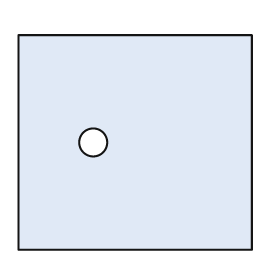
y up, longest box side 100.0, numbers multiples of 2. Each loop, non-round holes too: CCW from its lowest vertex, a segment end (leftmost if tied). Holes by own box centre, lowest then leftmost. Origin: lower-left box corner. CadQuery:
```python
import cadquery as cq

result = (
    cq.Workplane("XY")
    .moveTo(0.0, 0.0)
    .lineTo(100.0, 0.0)
    .lineTo(100.0, 92.0)
    .lineTo(0.0, 92.0)
    .close()
    .moveTo(32.0, 46.0)
    .circle(6.0)
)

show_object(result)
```